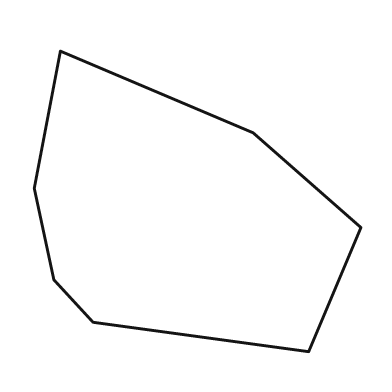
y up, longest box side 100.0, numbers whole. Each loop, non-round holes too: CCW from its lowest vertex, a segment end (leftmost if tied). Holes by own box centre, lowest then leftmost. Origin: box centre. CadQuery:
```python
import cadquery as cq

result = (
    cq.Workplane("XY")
    .moveTo(34.0, -46.0)
    .lineTo(50.0, -8.0)
    .lineTo(17.0, 21.0)
    .lineTo(-42.0, 46.0)
    .lineTo(-50.0, 4.0)
    .lineTo(-44.0, -24.0)
    .lineTo(-32.0, -37.0)
    .close()
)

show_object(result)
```